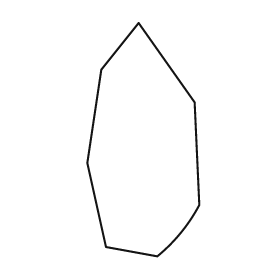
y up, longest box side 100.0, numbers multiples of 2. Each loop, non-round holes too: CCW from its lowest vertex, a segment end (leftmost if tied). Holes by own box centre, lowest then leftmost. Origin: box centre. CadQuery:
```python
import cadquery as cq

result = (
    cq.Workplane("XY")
    .moveTo(6.0, -50.0)
    .threePointArc((16.0, -40.0), (24.0, -28.0))
    .lineTo(22.0, 16.0)
    .lineTo(-2.0, 50.0)
    .lineTo(-18.0, 30.0)
    .lineTo(-24.0, -10.0)
    .lineTo(-16.0, -46.0)
    .close()
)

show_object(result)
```